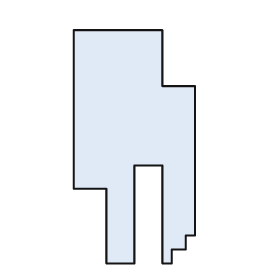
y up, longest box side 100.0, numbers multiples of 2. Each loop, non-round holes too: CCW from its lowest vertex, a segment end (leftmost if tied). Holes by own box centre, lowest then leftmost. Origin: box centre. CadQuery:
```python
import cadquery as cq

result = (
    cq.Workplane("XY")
    .moveTo(-12.0, -50.0)
    .lineTo(0.0, -50.0)
    .lineTo(0.0, -8.0)
    .lineTo(12.0, -8.0)
    .lineTo(12.0, -50.0)
    .lineTo(16.0, -50.0)
    .lineTo(16.0, -44.0)
    .lineTo(22.0, -44.0)
    .lineTo(22.0, -38.0)
    .lineTo(26.0, -38.0)
    .lineTo(26.0, 26.0)
    .lineTo(12.0, 26.0)
    .lineTo(12.0, 50.0)
    .lineTo(-26.0, 50.0)
    .lineTo(-26.0, -18.0)
    .lineTo(-12.0, -18.0)
    .close()
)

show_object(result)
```